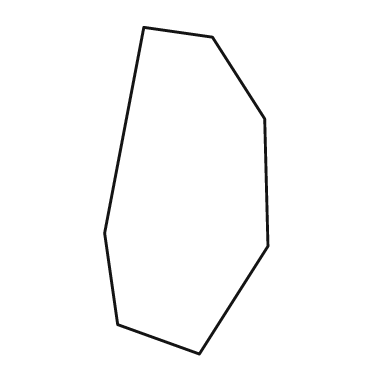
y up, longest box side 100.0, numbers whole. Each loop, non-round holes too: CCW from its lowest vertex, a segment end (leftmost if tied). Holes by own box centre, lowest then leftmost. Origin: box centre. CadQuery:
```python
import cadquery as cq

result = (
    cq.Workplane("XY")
    .moveTo(4.0, -50.0)
    .lineTo(25.0, -17.0)
    .lineTo(24.0, 22.0)
    .lineTo(8.0, 47.0)
    .lineTo(-13.0, 50.0)
    .lineTo(-25.0, -13.0)
    .lineTo(-21.0, -41.0)
    .close()
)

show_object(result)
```